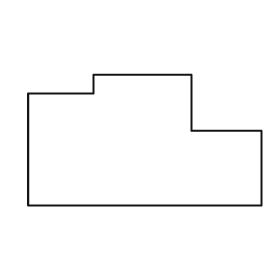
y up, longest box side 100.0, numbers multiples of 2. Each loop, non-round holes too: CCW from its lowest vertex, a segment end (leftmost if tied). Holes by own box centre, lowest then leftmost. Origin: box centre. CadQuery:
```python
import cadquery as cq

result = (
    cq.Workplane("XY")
    .moveTo(-50.0, -28.0)
    .lineTo(50.0, -28.0)
    .lineTo(50.0, 4.0)
    .lineTo(20.0, 4.0)
    .lineTo(20.0, 28.0)
    .lineTo(-22.0, 28.0)
    .lineTo(-22.0, 20.0)
    .lineTo(-50.0, 20.0)
    .close()
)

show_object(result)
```